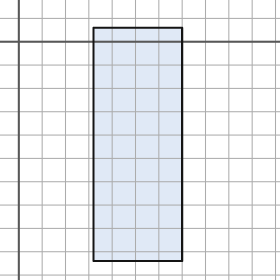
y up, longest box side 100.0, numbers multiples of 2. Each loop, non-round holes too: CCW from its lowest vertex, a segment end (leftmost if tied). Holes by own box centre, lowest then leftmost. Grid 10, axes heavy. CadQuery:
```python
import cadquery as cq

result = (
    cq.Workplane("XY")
    .moveTo(32.0, -94.0)
    .lineTo(70.0, -94.0)
    .lineTo(70.0, 6.0)
    .lineTo(32.0, 6.0)
    .close()
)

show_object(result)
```